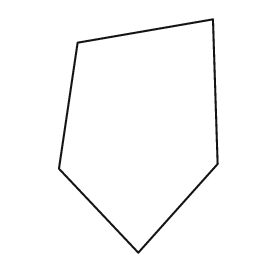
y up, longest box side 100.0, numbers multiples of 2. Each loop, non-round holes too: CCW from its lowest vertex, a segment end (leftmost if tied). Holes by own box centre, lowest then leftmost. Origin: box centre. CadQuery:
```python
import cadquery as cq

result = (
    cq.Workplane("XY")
    .moveTo(0.0, -50.0)
    .lineTo(34.0, -12.0)
    .lineTo(32.0, 50.0)
    .lineTo(-26.0, 40.0)
    .lineTo(-34.0, -14.0)
    .close()
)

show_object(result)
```